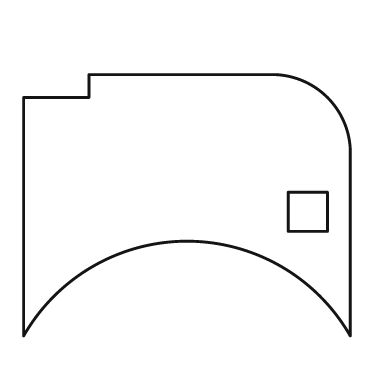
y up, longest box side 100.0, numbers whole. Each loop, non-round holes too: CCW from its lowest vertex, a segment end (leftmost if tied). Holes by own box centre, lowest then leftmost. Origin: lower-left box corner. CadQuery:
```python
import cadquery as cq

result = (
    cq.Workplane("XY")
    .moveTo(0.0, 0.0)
    .threePointArc((50.0, 29.0), (100.0, 0.0))
    .lineTo(100.0, 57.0)
    .threePointArc((93.0, 73.0), (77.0, 80.0))
    .lineTo(20.0, 80.0)
    .lineTo(20.0, 73.0)
    .lineTo(0.0, 73.0)
    .close()
    .moveTo(81.0, 32.0)
    .lineTo(93.0, 32.0)
    .lineTo(93.0, 44.0)
    .lineTo(81.0, 44.0)
    .close()
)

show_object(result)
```